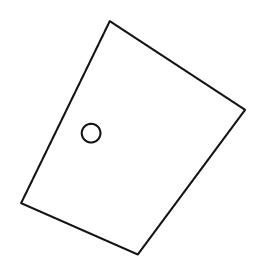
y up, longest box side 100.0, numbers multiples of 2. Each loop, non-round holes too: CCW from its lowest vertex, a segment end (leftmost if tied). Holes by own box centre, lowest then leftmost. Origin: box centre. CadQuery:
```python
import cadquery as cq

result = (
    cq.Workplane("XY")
    .moveTo(2.0, -50.0)
    .lineTo(48.0, 12.0)
    .lineTo(-10.0, 50.0)
    .lineTo(-48.0, -28.0)
    .close()
    .moveTo(-18.0, 2.0)
    .circle(4.0)
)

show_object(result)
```